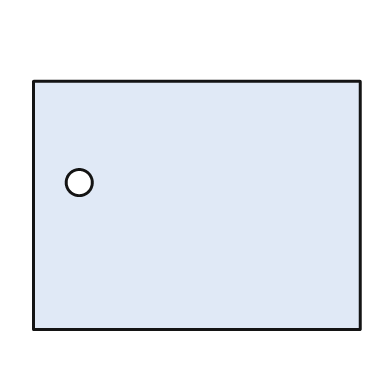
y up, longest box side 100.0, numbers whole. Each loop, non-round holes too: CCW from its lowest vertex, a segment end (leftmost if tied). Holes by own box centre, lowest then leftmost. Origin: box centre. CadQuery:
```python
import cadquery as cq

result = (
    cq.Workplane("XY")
    .moveTo(-50.0, -38.0)
    .lineTo(50.0, -38.0)
    .lineTo(50.0, 38.0)
    .lineTo(-50.0, 38.0)
    .close()
    .moveTo(-36.0, 7.0)
    .circle(4.0)
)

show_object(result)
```